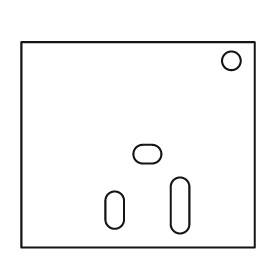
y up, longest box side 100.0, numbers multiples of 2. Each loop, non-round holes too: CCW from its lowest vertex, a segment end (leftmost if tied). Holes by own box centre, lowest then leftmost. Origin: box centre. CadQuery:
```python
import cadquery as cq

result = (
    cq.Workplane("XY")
    .moveTo(-50.0, -44.0)
    .lineTo(50.0, -44.0)
    .lineTo(50.0, 44.0)
    .lineTo(-50.0, 44.0)
    .close()
    .moveTo(-14.0, -32.0)
    .threePointArc((-10.0, -36.0), (-6.0, -32.0))
    .lineTo(-6.0, -24.0)
    .threePointArc((-10.0, -20.0), (-14.0, -24.0))
    .close()
    .moveTo(14.0, -34.0)
    .threePointArc((18.0, -38.0), (22.0, -34.0))
    .lineTo(22.0, -18.0)
    .threePointArc((18.0, -14.0), (14.0, -18.0))
    .close()
    .moveTo(2.0, -8.0)
    .lineTo(6.0, -8.0)
    .threePointArc((10.0, -4.0), (6.0, 0.0))
    .lineTo(2.0, 0.0)
    .threePointArc((-2.0, -4.0), (2.0, -8.0))
    .close()
    .moveTo(40.0, 36.0)
    .circle(4.0)
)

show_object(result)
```